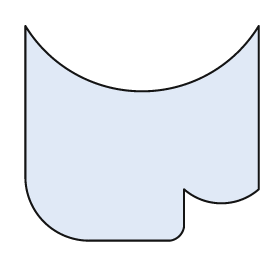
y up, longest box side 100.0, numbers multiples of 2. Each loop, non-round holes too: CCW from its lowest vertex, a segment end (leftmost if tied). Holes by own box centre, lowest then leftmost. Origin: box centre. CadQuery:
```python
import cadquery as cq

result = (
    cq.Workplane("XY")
    .moveTo(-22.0, -46.0)
    .lineTo(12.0, -46.0)
    .threePointArc((16.0, -44.0), (18.0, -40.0))
    .lineTo(18.0, -24.0)
    .threePointArc((34.0, -30.0), (50.0, -24.0))
    .lineTo(50.0, 46.0)
    .threePointArc((0.0, 18.0), (-50.0, 46.0))
    .lineTo(-50.0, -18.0)
    .threePointArc((-42.0, -38.0), (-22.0, -46.0))
    .close()
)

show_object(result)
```